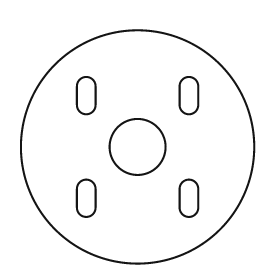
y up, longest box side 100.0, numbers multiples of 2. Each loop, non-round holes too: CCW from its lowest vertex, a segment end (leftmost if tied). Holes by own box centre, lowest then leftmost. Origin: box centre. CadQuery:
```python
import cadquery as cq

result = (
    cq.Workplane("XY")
    .moveTo(0.0, 0.0)
    .circle(50.0)
    .moveTo(-26.0, -26.0)
    .threePointArc((-22.0, -30.0), (-18.0, -26.0))
    .lineTo(-18.0, -18.0)
    .threePointArc((-22.0, -14.0), (-26.0, -18.0))
    .close()
    .moveTo(18.0, -26.0)
    .threePointArc((22.0, -30.0), (26.0, -26.0))
    .lineTo(26.0, -18.0)
    .threePointArc((22.0, -14.0), (18.0, -18.0))
    .close()
    .moveTo(0.0, 0.0)
    .circle(12.0)
    .moveTo(-26.0, 18.0)
    .threePointArc((-22.0, 14.0), (-18.0, 18.0))
    .lineTo(-18.0, 26.0)
    .threePointArc((-22.0, 30.0), (-26.0, 26.0))
    .close()
    .moveTo(18.0, 18.0)
    .threePointArc((22.0, 14.0), (26.0, 18.0))
    .lineTo(26.0, 26.0)
    .threePointArc((22.0, 30.0), (18.0, 26.0))
    .close()
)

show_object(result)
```